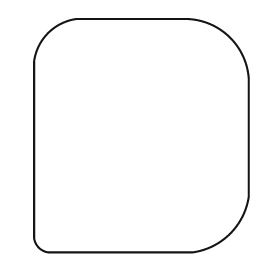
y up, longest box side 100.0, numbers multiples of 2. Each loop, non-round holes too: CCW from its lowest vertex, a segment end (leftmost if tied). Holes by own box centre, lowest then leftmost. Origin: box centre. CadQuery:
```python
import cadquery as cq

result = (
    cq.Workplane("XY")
    .moveTo(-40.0, -50.0)
    .lineTo(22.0, -50.0)
    .threePointArc((38.0, -42.0), (46.0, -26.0))
    .lineTo(46.0, 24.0)
    .threePointArc((38.0, 42.0), (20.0, 50.0))
    .lineTo(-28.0, 50.0)
    .threePointArc((-40.0, 44.0), (-46.0, 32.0))
    .lineTo(-46.0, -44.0)
    .threePointArc((-44.0, -48.0), (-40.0, -50.0))
    .close()
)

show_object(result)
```